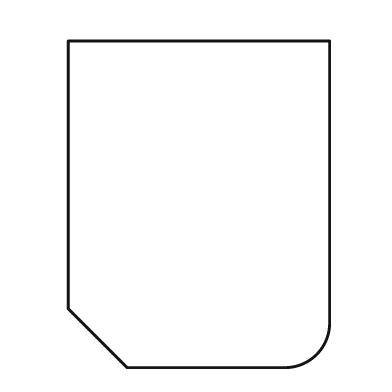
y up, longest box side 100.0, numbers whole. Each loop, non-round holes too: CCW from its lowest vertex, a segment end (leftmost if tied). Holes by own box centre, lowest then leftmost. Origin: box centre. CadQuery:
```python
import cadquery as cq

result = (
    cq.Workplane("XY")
    .moveTo(-22.0, -50.0)
    .lineTo(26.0, -50.0)
    .threePointArc((36.0, -46.0), (40.0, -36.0))
    .lineTo(40.0, 50.0)
    .lineTo(-40.0, 50.0)
    .lineTo(-40.0, -32.0)
    .close()
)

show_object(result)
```